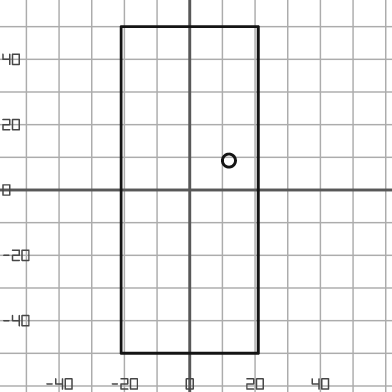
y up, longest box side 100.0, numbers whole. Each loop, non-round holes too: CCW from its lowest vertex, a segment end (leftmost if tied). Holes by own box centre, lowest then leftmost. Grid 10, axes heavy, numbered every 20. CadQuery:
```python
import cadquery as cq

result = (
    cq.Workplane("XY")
    .moveTo(-21.0, -50.0)
    .lineTo(21.0, -50.0)
    .lineTo(21.0, 50.0)
    .lineTo(-21.0, 50.0)
    .close()
    .moveTo(12.0, 9.0)
    .circle(2.0)
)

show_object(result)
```